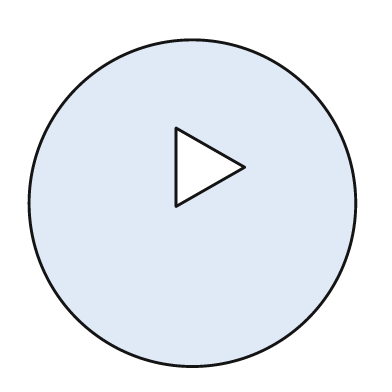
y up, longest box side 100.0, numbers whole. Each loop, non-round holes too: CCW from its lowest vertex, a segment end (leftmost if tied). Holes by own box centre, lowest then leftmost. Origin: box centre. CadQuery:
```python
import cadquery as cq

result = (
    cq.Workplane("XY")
    .moveTo(0.0, 0.0)
    .circle(50.0)
    .moveTo(-5.0, -1.0)
    .lineTo(16.0, 11.0)
    .lineTo(-5.0, 23.0)
    .close()
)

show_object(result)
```